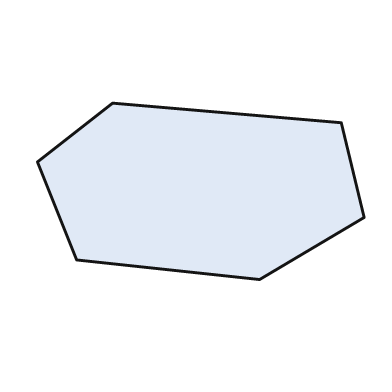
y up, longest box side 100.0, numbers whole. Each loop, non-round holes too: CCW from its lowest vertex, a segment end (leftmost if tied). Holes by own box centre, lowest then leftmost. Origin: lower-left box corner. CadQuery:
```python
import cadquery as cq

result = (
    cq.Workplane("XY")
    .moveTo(68.0, 0.0)
    .lineTo(100.0, 19.0)
    .lineTo(93.0, 48.0)
    .lineTo(23.0, 54.0)
    .lineTo(0.0, 36.0)
    .lineTo(12.0, 6.0)
    .close()
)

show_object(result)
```